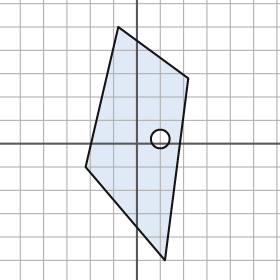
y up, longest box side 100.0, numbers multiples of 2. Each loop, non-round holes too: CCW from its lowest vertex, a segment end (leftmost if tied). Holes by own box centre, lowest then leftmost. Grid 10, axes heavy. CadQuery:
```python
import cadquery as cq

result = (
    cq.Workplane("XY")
    .moveTo(12.0, -50.0)
    .lineTo(22.0, 28.0)
    .lineTo(-8.0, 50.0)
    .lineTo(-22.0, -10.0)
    .close()
    .moveTo(10.0, 2.0)
    .circle(4.0)
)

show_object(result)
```